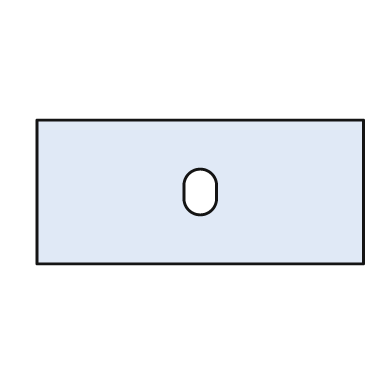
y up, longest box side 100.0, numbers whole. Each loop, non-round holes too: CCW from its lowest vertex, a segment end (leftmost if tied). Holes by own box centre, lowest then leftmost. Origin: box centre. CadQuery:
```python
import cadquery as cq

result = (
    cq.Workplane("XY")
    .moveTo(-50.0, -22.0)
    .lineTo(50.0, -22.0)
    .lineTo(50.0, 22.0)
    .lineTo(-50.0, 22.0)
    .close()
    .moveTo(-5.0, -2.0)
    .threePointArc((0.0, -7.0), (5.0, -2.0))
    .lineTo(5.0, 2.0)
    .threePointArc((0.0, 7.0), (-5.0, 2.0))
    .close()
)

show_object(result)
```